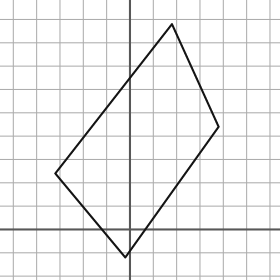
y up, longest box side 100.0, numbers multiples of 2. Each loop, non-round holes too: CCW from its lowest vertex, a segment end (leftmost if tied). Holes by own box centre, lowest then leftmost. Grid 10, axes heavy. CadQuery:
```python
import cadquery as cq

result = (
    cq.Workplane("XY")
    .moveTo(-2.0, -12.0)
    .lineTo(38.0, 44.0)
    .lineTo(18.0, 88.0)
    .lineTo(-32.0, 24.0)
    .close()
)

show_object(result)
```